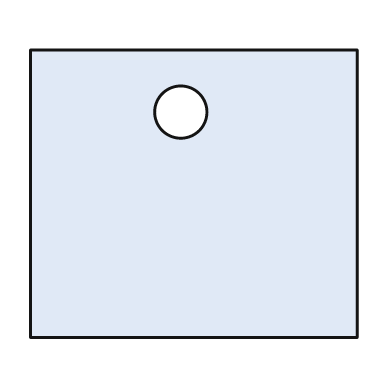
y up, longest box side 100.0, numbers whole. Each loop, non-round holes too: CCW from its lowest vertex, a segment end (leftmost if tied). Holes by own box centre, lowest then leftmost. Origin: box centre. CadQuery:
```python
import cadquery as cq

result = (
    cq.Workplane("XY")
    .moveTo(-50.0, -44.0)
    .lineTo(50.0, -44.0)
    .lineTo(50.0, 44.0)
    .lineTo(-50.0, 44.0)
    .close()
    .moveTo(-4.0, 25.0)
    .circle(8.0)
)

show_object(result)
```